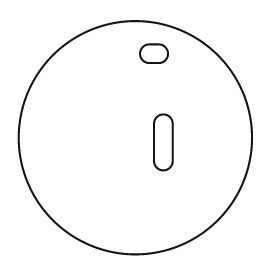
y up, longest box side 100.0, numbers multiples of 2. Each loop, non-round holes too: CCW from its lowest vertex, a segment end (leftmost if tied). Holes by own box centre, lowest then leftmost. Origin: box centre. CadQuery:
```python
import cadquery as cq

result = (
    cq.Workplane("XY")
    .moveTo(0.0, 0.0)
    .circle(50.0)
    .moveTo(8.0, -10.0)
    .threePointArc((12.0, -14.0), (16.0, -10.0))
    .lineTo(16.0, 6.0)
    .threePointArc((12.0, 10.0), (8.0, 6.0))
    .close()
    .moveTo(6.0, 32.0)
    .lineTo(10.0, 32.0)
    .threePointArc((14.0, 36.0), (10.0, 40.0))
    .lineTo(6.0, 40.0)
    .threePointArc((2.0, 36.0), (6.0, 32.0))
    .close()
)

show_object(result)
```